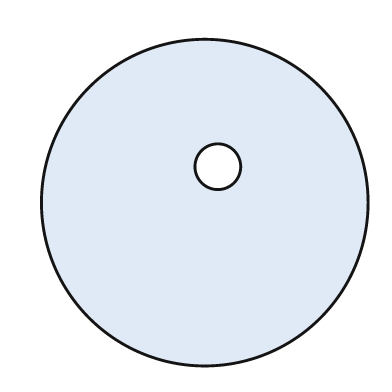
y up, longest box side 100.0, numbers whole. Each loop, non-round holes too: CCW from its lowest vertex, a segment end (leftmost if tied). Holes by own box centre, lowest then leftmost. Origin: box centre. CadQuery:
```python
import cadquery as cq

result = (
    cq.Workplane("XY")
    .moveTo(0.0, 0.0)
    .circle(50.0)
    .moveTo(4.0, 11.0)
    .circle(7.0)
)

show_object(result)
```